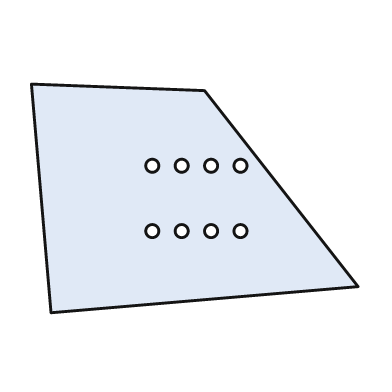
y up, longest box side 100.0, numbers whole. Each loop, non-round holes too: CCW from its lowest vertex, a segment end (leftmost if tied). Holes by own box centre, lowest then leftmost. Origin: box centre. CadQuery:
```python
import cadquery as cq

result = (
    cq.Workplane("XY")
    .moveTo(-44.0, -35.0)
    .lineTo(50.0, -27.0)
    .lineTo(3.0, 33.0)
    .lineTo(-50.0, 35.0)
    .close()
    .moveTo(-13.0, -10.0)
    .circle(2.0)
    .moveTo(-4.0, -10.0)
    .circle(2.0)
    .moveTo(5.0, -10.0)
    .circle(2.0)
    .moveTo(14.0, -10.0)
    .circle(2.0)
    .moveTo(-13.0, 10.0)
    .circle(2.0)
    .moveTo(-4.0, 10.0)
    .circle(2.0)
    .moveTo(5.0, 10.0)
    .circle(2.0)
    .moveTo(14.0, 10.0)
    .circle(2.0)
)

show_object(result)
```